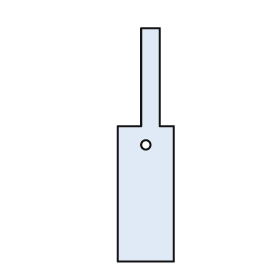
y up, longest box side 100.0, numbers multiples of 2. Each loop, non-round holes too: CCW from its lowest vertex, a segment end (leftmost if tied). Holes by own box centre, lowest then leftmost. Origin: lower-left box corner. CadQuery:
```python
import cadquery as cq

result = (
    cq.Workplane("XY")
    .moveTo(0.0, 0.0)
    .lineTo(24.0, 0.0)
    .lineTo(24.0, 58.0)
    .lineTo(18.0, 58.0)
    .lineTo(18.0, 100.0)
    .lineTo(10.0, 100.0)
    .lineTo(10.0, 58.0)
    .lineTo(0.0, 58.0)
    .close()
    .moveTo(12.0, 50.0)
    .circle(2.0)
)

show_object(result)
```